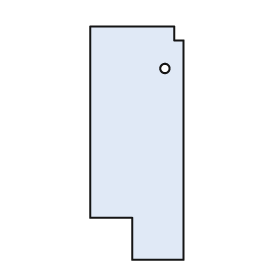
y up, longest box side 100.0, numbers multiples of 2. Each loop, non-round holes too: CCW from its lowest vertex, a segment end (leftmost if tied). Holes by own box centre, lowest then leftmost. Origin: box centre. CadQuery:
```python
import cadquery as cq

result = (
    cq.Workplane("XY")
    .moveTo(-2.0, -50.0)
    .lineTo(20.0, -50.0)
    .lineTo(20.0, 44.0)
    .lineTo(16.0, 44.0)
    .lineTo(16.0, 50.0)
    .lineTo(-20.0, 50.0)
    .lineTo(-20.0, -32.0)
    .lineTo(-2.0, -32.0)
    .close()
    .moveTo(12.0, 32.0)
    .circle(2.0)
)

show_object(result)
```